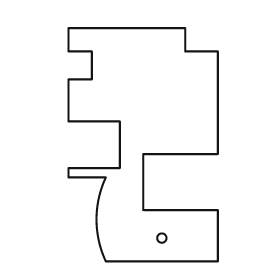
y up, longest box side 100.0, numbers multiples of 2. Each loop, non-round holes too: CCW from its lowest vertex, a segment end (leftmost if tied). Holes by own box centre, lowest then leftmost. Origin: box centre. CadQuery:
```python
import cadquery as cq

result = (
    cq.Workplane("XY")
    .moveTo(-16.0, -50.0)
    .lineTo(32.0, -50.0)
    .lineTo(32.0, -28.0)
    .lineTo(0.0, -28.0)
    .lineTo(0.0, -4.0)
    .lineTo(32.0, -4.0)
    .lineTo(32.0, 40.0)
    .lineTo(18.0, 40.0)
    .lineTo(18.0, 50.0)
    .lineTo(-32.0, 50.0)
    .lineTo(-32.0, 40.0)
    .lineTo(-22.0, 40.0)
    .lineTo(-22.0, 28.0)
    .lineTo(-32.0, 28.0)
    .lineTo(-32.0, 10.0)
    .lineTo(-10.0, 10.0)
    .lineTo(-10.0, -10.0)
    .lineTo(-32.0, -10.0)
    .lineTo(-32.0, -14.0)
    .lineTo(-16.0, -14.0)
    .threePointArc((-20.0, -32.0), (-16.0, -50.0))
    .close()
    .moveTo(8.0, -40.0)
    .circle(2.0)
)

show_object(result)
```